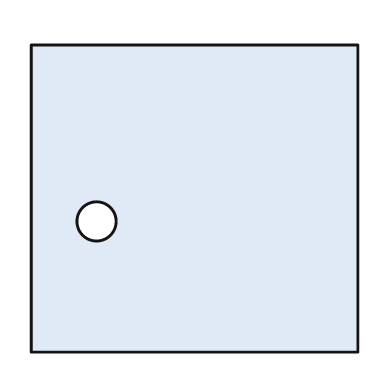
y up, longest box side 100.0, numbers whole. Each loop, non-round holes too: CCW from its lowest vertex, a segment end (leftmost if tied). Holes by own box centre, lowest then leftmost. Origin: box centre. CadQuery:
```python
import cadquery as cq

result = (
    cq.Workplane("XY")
    .moveTo(-50.0, -47.0)
    .lineTo(50.0, -47.0)
    .lineTo(50.0, 47.0)
    .lineTo(-50.0, 47.0)
    .close()
    .moveTo(-30.0, -7.0)
    .circle(6.0)
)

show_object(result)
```